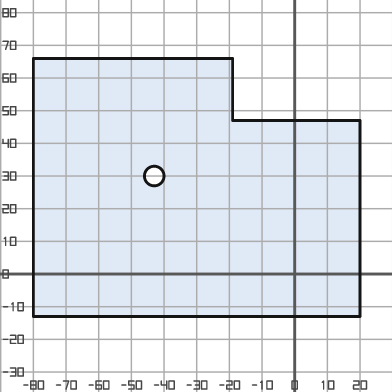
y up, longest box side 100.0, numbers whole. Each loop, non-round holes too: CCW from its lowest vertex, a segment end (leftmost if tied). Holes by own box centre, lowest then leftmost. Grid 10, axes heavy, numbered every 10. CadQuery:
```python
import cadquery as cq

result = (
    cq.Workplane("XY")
    .moveTo(-80.0, -13.0)
    .lineTo(20.0, -13.0)
    .lineTo(20.0, 47.0)
    .lineTo(-19.0, 47.0)
    .lineTo(-19.0, 66.0)
    .lineTo(-80.0, 66.0)
    .close()
    .moveTo(-43.0, 30.0)
    .circle(3.0)
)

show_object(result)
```